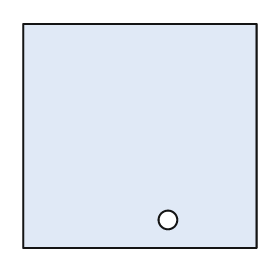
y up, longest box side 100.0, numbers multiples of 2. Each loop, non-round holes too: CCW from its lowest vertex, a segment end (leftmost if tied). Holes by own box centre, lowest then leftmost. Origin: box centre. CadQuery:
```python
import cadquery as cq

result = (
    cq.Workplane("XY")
    .moveTo(-50.0, -48.0)
    .lineTo(50.0, -48.0)
    .lineTo(50.0, 48.0)
    .lineTo(-50.0, 48.0)
    .close()
    .moveTo(12.0, -36.0)
    .circle(4.0)
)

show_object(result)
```